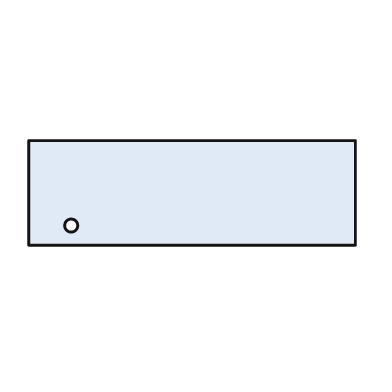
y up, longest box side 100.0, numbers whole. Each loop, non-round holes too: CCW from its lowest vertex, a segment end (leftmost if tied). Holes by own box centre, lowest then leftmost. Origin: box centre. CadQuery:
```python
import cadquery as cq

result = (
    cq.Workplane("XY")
    .moveTo(-50.0, -16.0)
    .lineTo(50.0, -16.0)
    .lineTo(50.0, 16.0)
    .lineTo(-50.0, 16.0)
    .close()
    .moveTo(-37.0, -10.0)
    .circle(2.0)
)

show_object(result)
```